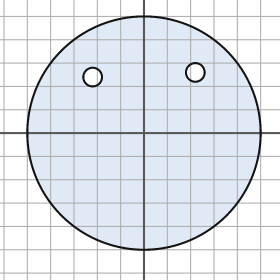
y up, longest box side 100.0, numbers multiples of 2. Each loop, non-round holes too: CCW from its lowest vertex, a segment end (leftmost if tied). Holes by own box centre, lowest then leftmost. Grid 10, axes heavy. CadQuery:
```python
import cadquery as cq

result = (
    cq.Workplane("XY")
    .moveTo(0.0, 0.0)
    .circle(50.0)
    .moveTo(-22.0, 24.0)
    .circle(4.0)
    .moveTo(22.0, 26.0)
    .circle(4.0)
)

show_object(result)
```